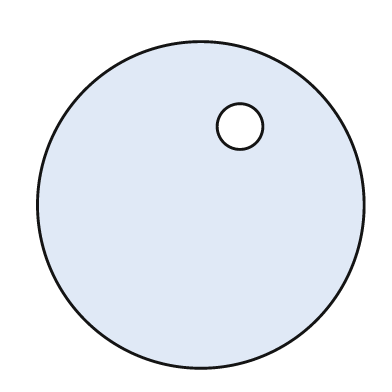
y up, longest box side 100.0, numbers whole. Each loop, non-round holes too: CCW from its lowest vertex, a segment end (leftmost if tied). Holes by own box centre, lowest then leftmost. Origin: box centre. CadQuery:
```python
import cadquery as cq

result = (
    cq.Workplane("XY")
    .moveTo(0.0, 0.0)
    .circle(50.0)
    .moveTo(12.0, 24.0)
    .circle(7.0)
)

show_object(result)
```